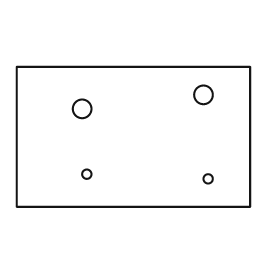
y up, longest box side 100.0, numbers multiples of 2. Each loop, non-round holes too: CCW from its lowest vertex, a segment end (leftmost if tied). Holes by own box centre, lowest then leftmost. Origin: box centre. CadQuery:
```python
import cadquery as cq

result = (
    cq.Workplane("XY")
    .moveTo(-50.0, -30.0)
    .lineTo(50.0, -30.0)
    .lineTo(50.0, 30.0)
    .lineTo(-50.0, 30.0)
    .close()
    .moveTo(32.0, -18.0)
    .circle(2.0)
    .moveTo(-20.0, -16.0)
    .circle(2.0)
    .moveTo(-22.0, 12.0)
    .circle(4.0)
    .moveTo(30.0, 18.0)
    .circle(4.0)
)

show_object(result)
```